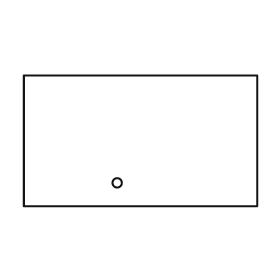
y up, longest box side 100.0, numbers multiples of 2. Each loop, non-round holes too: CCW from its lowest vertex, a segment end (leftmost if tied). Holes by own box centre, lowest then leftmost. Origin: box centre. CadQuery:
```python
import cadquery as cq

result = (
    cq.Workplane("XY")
    .moveTo(-50.0, -28.0)
    .lineTo(50.0, -28.0)
    .lineTo(50.0, 28.0)
    .lineTo(-50.0, 28.0)
    .close()
    .moveTo(-10.0, -18.0)
    .circle(2.0)
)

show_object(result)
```